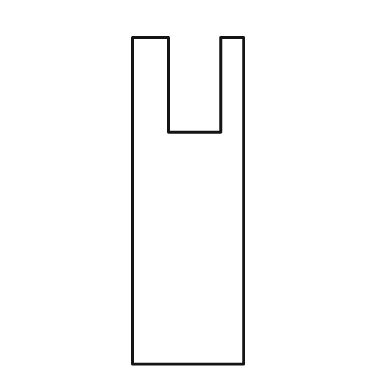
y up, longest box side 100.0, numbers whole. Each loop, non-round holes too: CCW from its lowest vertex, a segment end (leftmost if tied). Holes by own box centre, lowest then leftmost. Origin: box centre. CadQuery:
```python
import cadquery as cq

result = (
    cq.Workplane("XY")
    .moveTo(-17.0, -50.0)
    .lineTo(17.0, -50.0)
    .lineTo(17.0, 50.0)
    .lineTo(10.0, 50.0)
    .lineTo(10.0, 21.0)
    .lineTo(-6.0, 21.0)
    .lineTo(-6.0, 50.0)
    .lineTo(-17.0, 50.0)
    .close()
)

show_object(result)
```